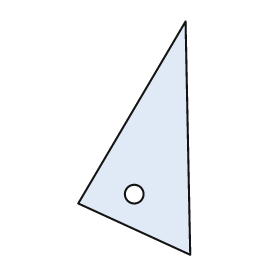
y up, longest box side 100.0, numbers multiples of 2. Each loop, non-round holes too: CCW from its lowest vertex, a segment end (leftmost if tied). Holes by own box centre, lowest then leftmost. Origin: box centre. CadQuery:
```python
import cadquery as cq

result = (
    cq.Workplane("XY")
    .moveTo(24.0, -50.0)
    .lineTo(22.0, 50.0)
    .lineTo(-24.0, -28.0)
    .close()
    .moveTo(0.0, -24.0)
    .circle(4.0)
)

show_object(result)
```